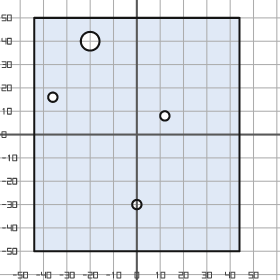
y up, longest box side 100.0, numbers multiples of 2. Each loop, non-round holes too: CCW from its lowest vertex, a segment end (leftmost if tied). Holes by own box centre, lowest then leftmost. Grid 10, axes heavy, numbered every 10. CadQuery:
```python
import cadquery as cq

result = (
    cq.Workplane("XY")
    .moveTo(-44.0, -50.0)
    .lineTo(44.0, -50.0)
    .lineTo(44.0, 50.0)
    .lineTo(-44.0, 50.0)
    .close()
    .moveTo(0.0, -30.0)
    .circle(2.0)
    .moveTo(12.0, 8.0)
    .circle(2.0)
    .moveTo(-36.0, 16.0)
    .circle(2.0)
    .moveTo(-20.0, 40.0)
    .circle(4.0)
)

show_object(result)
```